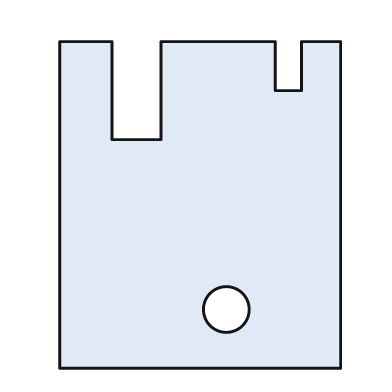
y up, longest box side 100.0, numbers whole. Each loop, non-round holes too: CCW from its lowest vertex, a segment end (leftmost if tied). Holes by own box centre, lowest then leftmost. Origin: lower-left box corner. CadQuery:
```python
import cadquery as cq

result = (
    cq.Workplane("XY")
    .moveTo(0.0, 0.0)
    .lineTo(86.0, 0.0)
    .lineTo(86.0, 100.0)
    .lineTo(74.0, 100.0)
    .lineTo(74.0, 85.0)
    .lineTo(66.0, 85.0)
    .lineTo(66.0, 100.0)
    .lineTo(31.0, 100.0)
    .lineTo(31.0, 70.0)
    .lineTo(16.0, 70.0)
    .lineTo(16.0, 100.0)
    .lineTo(0.0, 100.0)
    .close()
    .moveTo(51.0, 18.0)
    .circle(7.0)
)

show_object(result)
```